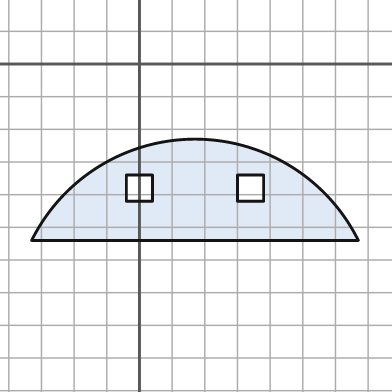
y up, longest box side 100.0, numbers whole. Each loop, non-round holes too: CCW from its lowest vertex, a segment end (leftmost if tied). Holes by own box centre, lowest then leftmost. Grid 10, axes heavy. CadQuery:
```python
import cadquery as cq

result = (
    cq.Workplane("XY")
    .moveTo(-33.0, -54.0)
    .lineTo(67.0, -54.0)
    .threePointArc((17.0, -23.0), (-33.0, -54.0))
    .close()
    .moveTo(-4.0, -42.0)
    .lineTo(4.0, -42.0)
    .lineTo(4.0, -34.0)
    .lineTo(-4.0, -34.0)
    .close()
    .moveTo(30.0, -42.0)
    .lineTo(38.0, -42.0)
    .lineTo(38.0, -34.0)
    .lineTo(30.0, -34.0)
    .close()
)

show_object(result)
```